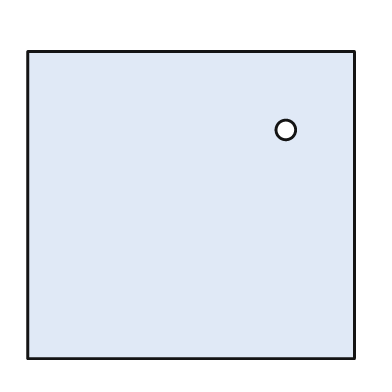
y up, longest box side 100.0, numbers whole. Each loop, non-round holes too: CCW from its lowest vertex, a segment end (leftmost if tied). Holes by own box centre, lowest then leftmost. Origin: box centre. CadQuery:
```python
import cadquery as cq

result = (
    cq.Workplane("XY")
    .moveTo(-50.0, -47.0)
    .lineTo(50.0, -47.0)
    .lineTo(50.0, 47.0)
    .lineTo(-50.0, 47.0)
    .close()
    .moveTo(29.0, 23.0)
    .circle(3.0)
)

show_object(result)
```